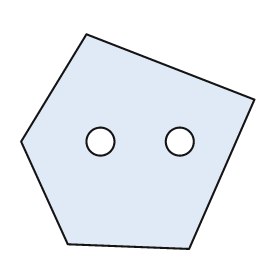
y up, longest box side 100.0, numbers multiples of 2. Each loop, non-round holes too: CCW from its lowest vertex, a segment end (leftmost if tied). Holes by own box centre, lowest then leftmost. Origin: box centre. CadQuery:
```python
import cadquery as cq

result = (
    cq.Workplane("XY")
    .moveTo(22.0, -46.0)
    .lineTo(50.0, 18.0)
    .lineTo(-22.0, 46.0)
    .lineTo(-50.0, 0.0)
    .lineTo(-30.0, -44.0)
    .close()
    .moveTo(-16.0, 0.0)
    .circle(6.0)
    .moveTo(18.0, 0.0)
    .circle(6.0)
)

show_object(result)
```